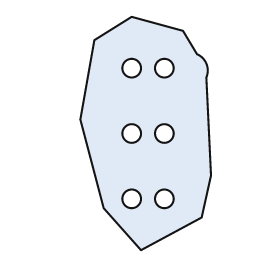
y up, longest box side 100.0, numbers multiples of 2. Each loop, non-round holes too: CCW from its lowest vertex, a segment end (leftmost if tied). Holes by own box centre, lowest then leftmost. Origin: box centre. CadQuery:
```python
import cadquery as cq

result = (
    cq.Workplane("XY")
    .moveTo(-2.0, -50.0)
    .lineTo(24.0, -36.0)
    .lineTo(28.0, -18.0)
    .lineTo(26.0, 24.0)
    .threePointArc((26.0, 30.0), (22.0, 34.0))
    .lineTo(16.0, 44.0)
    .lineTo(-6.0, 50.0)
    .lineTo(-22.0, 40.0)
    .lineTo(-28.0, 6.0)
    .lineTo(-18.0, -32.0)
    .close()
    .moveTo(-6.0, -28.0)
    .circle(4.0)
    .moveTo(8.0, -28.0)
    .circle(4.0)
    .moveTo(-6.0, 0.0)
    .circle(4.0)
    .moveTo(8.0, 0.0)
    .circle(4.0)
    .moveTo(-6.0, 28.0)
    .circle(4.0)
    .moveTo(8.0, 28.0)
    .circle(4.0)
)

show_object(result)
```